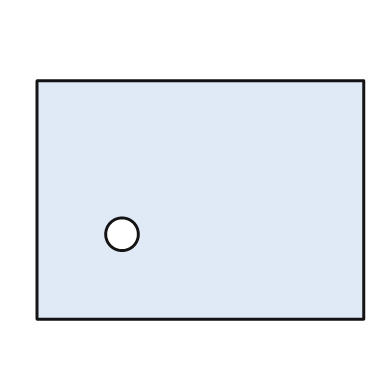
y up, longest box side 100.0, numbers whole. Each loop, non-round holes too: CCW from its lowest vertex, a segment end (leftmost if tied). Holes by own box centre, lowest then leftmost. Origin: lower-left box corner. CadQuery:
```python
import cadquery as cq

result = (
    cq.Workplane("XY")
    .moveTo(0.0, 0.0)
    .lineTo(100.0, 0.0)
    .lineTo(100.0, 73.0)
    .lineTo(0.0, 73.0)
    .close()
    .moveTo(26.0, 26.0)
    .circle(5.0)
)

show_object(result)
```